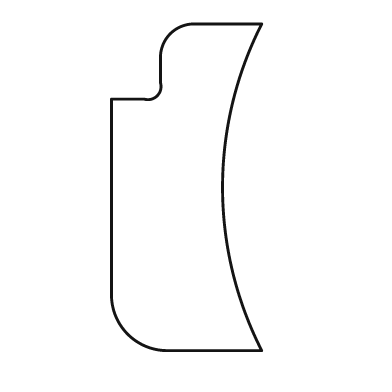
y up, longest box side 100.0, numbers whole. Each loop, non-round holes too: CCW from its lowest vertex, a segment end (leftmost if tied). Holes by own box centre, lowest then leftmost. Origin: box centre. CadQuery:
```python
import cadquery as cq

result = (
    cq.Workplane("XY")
    .moveTo(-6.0, -50.0)
    .lineTo(23.0, -50.0)
    .threePointArc((11.0, 0.0), (23.0, 50.0))
    .lineTo(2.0, 50.0)
    .threePointArc((-5.0, 47.0), (-8.0, 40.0))
    .lineTo(-8.0, 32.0)
    .threePointArc((-9.0, 28.0), (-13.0, 27.0))
    .lineTo(-23.0, 27.0)
    .lineTo(-23.0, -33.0)
    .threePointArc((-18.0, -45.0), (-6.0, -50.0))
    .close()
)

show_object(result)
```